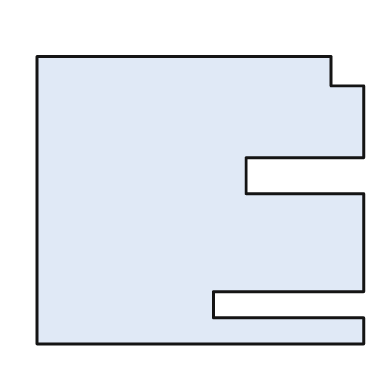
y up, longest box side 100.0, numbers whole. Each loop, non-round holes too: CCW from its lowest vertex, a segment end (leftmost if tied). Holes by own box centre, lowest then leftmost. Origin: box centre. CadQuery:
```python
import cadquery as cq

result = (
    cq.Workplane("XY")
    .moveTo(-50.0, -44.0)
    .lineTo(50.0, -44.0)
    .lineTo(50.0, -36.0)
    .lineTo(4.0, -36.0)
    .lineTo(4.0, -28.0)
    .lineTo(50.0, -28.0)
    .lineTo(50.0, 2.0)
    .lineTo(14.0, 2.0)
    .lineTo(14.0, 13.0)
    .lineTo(50.0, 13.0)
    .lineTo(50.0, 35.0)
    .lineTo(40.0, 35.0)
    .lineTo(40.0, 44.0)
    .lineTo(-50.0, 44.0)
    .close()
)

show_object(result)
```